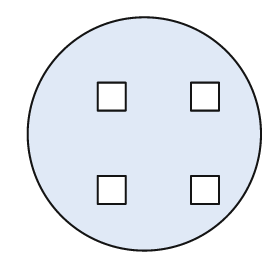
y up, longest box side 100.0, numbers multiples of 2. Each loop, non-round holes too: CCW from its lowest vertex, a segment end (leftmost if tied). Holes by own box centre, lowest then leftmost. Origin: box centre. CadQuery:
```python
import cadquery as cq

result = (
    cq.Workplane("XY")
    .moveTo(0.0, 0.0)
    .circle(50.0)
    .moveTo(-20.0, -30.0)
    .lineTo(-8.0, -30.0)
    .lineTo(-8.0, -18.0)
    .lineTo(-20.0, -18.0)
    .close()
    .moveTo(20.0, -30.0)
    .lineTo(32.0, -30.0)
    .lineTo(32.0, -18.0)
    .lineTo(20.0, -18.0)
    .close()
    .moveTo(-20.0, 10.0)
    .lineTo(-8.0, 10.0)
    .lineTo(-8.0, 22.0)
    .lineTo(-20.0, 22.0)
    .close()
    .moveTo(20.0, 10.0)
    .lineTo(32.0, 10.0)
    .lineTo(32.0, 22.0)
    .lineTo(20.0, 22.0)
    .close()
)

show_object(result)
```